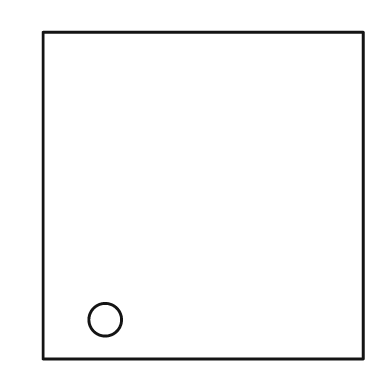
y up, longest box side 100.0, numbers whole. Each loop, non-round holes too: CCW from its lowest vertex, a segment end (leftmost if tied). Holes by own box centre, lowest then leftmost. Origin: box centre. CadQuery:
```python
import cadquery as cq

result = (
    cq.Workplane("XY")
    .moveTo(-49.0, -50.0)
    .lineTo(49.0, -50.0)
    .lineTo(49.0, 50.0)
    .lineTo(-49.0, 50.0)
    .close()
    .moveTo(-30.0, -38.0)
    .circle(5.0)
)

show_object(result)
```